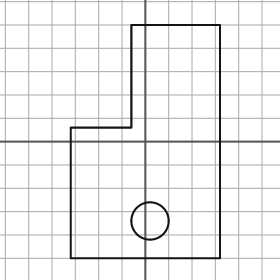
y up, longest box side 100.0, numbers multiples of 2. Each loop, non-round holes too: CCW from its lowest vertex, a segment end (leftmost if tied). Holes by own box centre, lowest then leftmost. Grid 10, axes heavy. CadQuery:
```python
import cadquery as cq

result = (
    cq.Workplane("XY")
    .moveTo(-32.0, -50.0)
    .lineTo(32.0, -50.0)
    .lineTo(32.0, 50.0)
    .lineTo(-6.0, 50.0)
    .lineTo(-6.0, 6.0)
    .lineTo(-32.0, 6.0)
    .close()
    .moveTo(2.0, -34.0)
    .circle(8.0)
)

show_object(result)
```